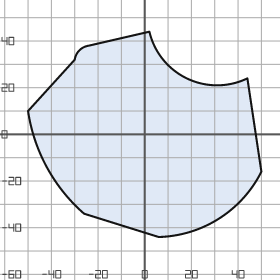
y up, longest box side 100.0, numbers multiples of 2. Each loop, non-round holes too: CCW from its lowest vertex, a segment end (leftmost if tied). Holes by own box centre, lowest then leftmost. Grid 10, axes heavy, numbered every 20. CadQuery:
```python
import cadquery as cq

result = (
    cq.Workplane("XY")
    .moveTo(6.0, -44.0)
    .threePointArc((32.0, -36.0), (50.0, -16.0))
    .lineTo(44.0, 24.0)
    .threePointArc((18.0, 24.0), (2.0, 44.0))
    .lineTo(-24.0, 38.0)
    .threePointArc((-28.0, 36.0), (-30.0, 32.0))
    .lineTo(-50.0, 10.0)
    .threePointArc((-42.0, -14.0), (-26.0, -34.0))
    .close()
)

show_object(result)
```